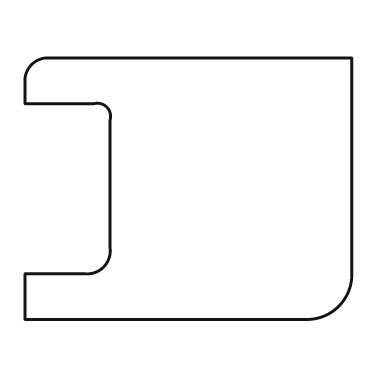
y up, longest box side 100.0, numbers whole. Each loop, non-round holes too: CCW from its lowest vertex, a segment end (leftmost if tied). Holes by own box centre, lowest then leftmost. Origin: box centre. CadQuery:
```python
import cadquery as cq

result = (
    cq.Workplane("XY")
    .moveTo(-50.0, -40.0)
    .lineTo(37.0, -40.0)
    .threePointArc((46.0, -36.0), (50.0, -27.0))
    .lineTo(50.0, 40.0)
    .lineTo(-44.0, 40.0)
    .threePointArc((-48.0, 38.0), (-50.0, 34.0))
    .lineTo(-50.0, 26.0)
    .lineTo(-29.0, 26.0)
    .threePointArc((-25.0, 25.0), (-24.0, 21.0))
    .lineTo(-24.0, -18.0)
    .threePointArc((-26.0, -24.0), (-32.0, -26.0))
    .lineTo(-50.0, -26.0)
    .close()
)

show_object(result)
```